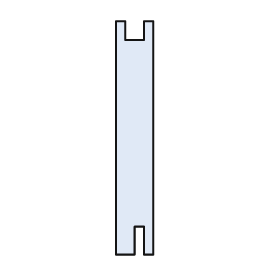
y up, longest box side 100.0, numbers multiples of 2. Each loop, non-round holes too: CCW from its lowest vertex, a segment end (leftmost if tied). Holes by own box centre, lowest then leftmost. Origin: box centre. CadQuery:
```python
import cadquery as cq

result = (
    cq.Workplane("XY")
    .moveTo(-8.0, -50.0)
    .lineTo(0.0, -50.0)
    .lineTo(0.0, -38.0)
    .lineTo(4.0, -38.0)
    .lineTo(4.0, -50.0)
    .lineTo(8.0, -50.0)
    .lineTo(8.0, 50.0)
    .lineTo(4.0, 50.0)
    .lineTo(4.0, 42.0)
    .lineTo(-4.0, 42.0)
    .lineTo(-4.0, 50.0)
    .lineTo(-8.0, 50.0)
    .close()
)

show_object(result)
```